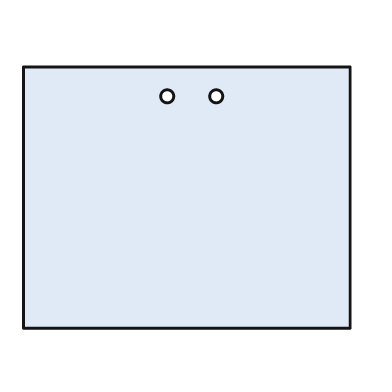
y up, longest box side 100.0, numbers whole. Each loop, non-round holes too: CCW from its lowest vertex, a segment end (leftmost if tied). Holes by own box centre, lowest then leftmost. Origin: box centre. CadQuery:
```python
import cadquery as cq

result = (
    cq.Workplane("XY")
    .moveTo(-50.0, -40.0)
    .lineTo(50.0, -40.0)
    .lineTo(50.0, 40.0)
    .lineTo(-50.0, 40.0)
    .close()
    .moveTo(-6.0, 31.0)
    .circle(2.0)
    .moveTo(9.0, 31.0)
    .circle(2.0)
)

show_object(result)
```